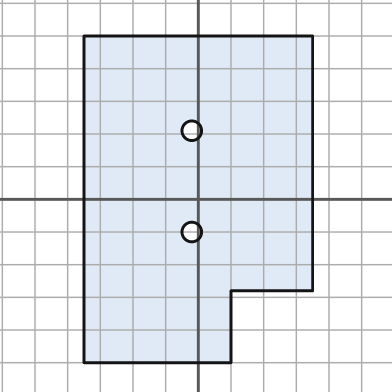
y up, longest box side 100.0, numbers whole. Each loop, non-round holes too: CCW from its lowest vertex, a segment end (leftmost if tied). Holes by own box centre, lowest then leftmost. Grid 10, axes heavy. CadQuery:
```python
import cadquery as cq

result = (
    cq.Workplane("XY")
    .moveTo(-35.0, -50.0)
    .lineTo(10.0, -50.0)
    .lineTo(10.0, -28.0)
    .lineTo(35.0, -28.0)
    .lineTo(35.0, 50.0)
    .lineTo(-35.0, 50.0)
    .close()
    .moveTo(-2.0, -10.0)
    .circle(3.0)
    .moveTo(-2.0, 21.0)
    .circle(3.0)
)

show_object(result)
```